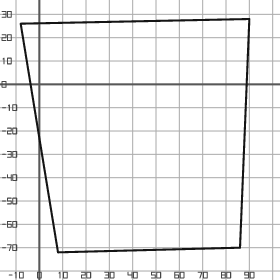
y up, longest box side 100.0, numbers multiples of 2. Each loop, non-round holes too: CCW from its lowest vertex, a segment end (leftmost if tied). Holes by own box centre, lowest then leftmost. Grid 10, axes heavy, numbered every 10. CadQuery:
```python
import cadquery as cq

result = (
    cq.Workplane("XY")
    .moveTo(8.0, -72.0)
    .lineTo(86.0, -70.0)
    .lineTo(90.0, 28.0)
    .lineTo(-8.0, 26.0)
    .close()
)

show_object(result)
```